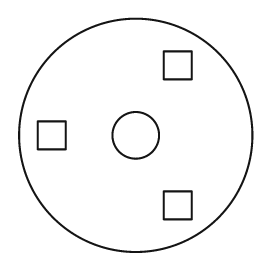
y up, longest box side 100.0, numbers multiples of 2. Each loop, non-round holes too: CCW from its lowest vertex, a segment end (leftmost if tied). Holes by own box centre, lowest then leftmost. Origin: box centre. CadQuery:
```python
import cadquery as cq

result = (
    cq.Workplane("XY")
    .moveTo(0.0, 0.0)
    .circle(50.0)
    .moveTo(12.0, -36.0)
    .lineTo(24.0, -36.0)
    .lineTo(24.0, -24.0)
    .lineTo(12.0, -24.0)
    .close()
    .moveTo(-42.0, -6.0)
    .lineTo(-30.0, -6.0)
    .lineTo(-30.0, 6.0)
    .lineTo(-42.0, 6.0)
    .close()
    .moveTo(0.0, 0.0)
    .circle(10.0)
    .moveTo(12.0, 24.0)
    .lineTo(24.0, 24.0)
    .lineTo(24.0, 36.0)
    .lineTo(12.0, 36.0)
    .close()
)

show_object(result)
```